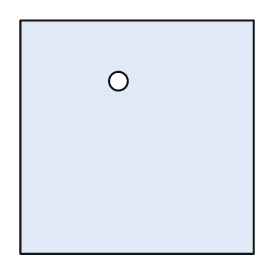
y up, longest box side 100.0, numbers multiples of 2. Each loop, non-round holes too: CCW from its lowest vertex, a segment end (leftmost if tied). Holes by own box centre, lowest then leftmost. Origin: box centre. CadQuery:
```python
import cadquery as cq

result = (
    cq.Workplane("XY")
    .moveTo(-50.0, -50.0)
    .lineTo(50.0, -50.0)
    .lineTo(50.0, 50.0)
    .lineTo(-50.0, 50.0)
    .close()
    .moveTo(-8.0, 24.0)
    .circle(4.0)
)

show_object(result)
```